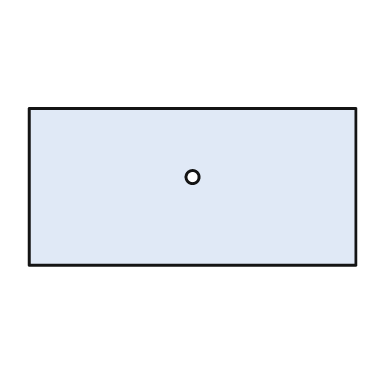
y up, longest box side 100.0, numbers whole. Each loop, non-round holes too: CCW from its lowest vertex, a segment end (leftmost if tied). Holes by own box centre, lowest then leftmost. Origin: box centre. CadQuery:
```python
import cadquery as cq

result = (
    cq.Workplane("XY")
    .moveTo(-50.0, -24.0)
    .lineTo(50.0, -24.0)
    .lineTo(50.0, 24.0)
    .lineTo(-50.0, 24.0)
    .close()
    .moveTo(0.0, 3.0)
    .circle(2.0)
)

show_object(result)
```